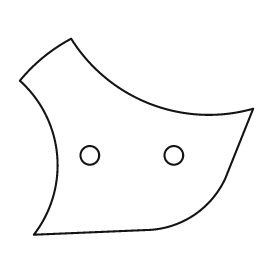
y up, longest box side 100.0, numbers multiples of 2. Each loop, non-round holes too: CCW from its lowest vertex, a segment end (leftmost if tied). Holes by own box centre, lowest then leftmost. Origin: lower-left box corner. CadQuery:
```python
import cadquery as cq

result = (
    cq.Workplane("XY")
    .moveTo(6.0, 0.0)
    .lineTo(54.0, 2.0)
    .threePointArc((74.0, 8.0), (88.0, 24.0))
    .lineTo(100.0, 54.0)
    .threePointArc((56.0, 56.0), (22.0, 84.0))
    .threePointArc((10.0, 76.0), (0.0, 66.0))
    .threePointArc((16.0, 34.0), (6.0, 0.0))
    .close()
    .moveTo(30.0, 34.0)
    .circle(4.0)
    .moveTo(66.0, 34.0)
    .circle(4.0)
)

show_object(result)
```